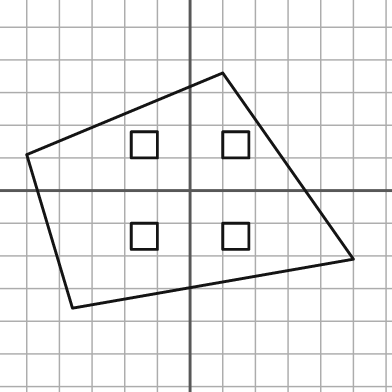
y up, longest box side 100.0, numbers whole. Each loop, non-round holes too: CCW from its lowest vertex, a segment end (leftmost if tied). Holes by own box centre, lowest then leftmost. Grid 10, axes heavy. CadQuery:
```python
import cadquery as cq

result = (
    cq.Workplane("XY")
    .moveTo(-36.0, -36.0)
    .lineTo(50.0, -21.0)
    .lineTo(10.0, 36.0)
    .lineTo(-50.0, 11.0)
    .close()
    .moveTo(-18.0, -18.0)
    .lineTo(-10.0, -18.0)
    .lineTo(-10.0, -10.0)
    .lineTo(-18.0, -10.0)
    .close()
    .moveTo(10.0, -18.0)
    .lineTo(18.0, -18.0)
    .lineTo(18.0, -10.0)
    .lineTo(10.0, -10.0)
    .close()
    .moveTo(-18.0, 10.0)
    .lineTo(-10.0, 10.0)
    .lineTo(-10.0, 18.0)
    .lineTo(-18.0, 18.0)
    .close()
    .moveTo(10.0, 10.0)
    .lineTo(18.0, 10.0)
    .lineTo(18.0, 18.0)
    .lineTo(10.0, 18.0)
    .close()
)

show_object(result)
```